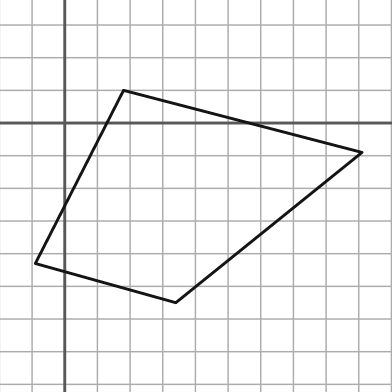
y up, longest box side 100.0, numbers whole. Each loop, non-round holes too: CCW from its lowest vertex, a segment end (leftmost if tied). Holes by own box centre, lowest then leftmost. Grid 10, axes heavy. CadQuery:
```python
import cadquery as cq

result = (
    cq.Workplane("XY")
    .moveTo(34.0, -55.0)
    .lineTo(91.0, -9.0)
    .lineTo(18.0, 10.0)
    .lineTo(-9.0, -43.0)
    .close()
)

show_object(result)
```